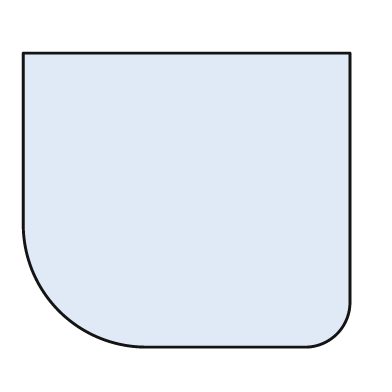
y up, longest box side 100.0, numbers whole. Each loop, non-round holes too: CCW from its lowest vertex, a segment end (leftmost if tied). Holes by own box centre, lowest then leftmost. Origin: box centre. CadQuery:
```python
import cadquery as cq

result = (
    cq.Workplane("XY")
    .moveTo(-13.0, -45.0)
    .lineTo(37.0, -45.0)
    .threePointArc((46.0, -41.0), (50.0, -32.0))
    .lineTo(50.0, 45.0)
    .lineTo(-50.0, 45.0)
    .lineTo(-50.0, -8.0)
    .threePointArc((-39.0, -34.0), (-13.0, -45.0))
    .close()
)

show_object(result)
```